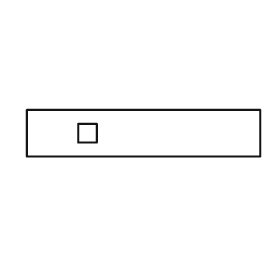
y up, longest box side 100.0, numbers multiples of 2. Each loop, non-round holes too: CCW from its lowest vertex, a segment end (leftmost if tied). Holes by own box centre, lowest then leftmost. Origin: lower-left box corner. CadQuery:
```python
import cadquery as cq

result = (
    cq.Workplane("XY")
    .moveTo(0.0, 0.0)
    .lineTo(100.0, 0.0)
    .lineTo(100.0, 20.0)
    .lineTo(0.0, 20.0)
    .close()
    .moveTo(22.0, 6.0)
    .lineTo(30.0, 6.0)
    .lineTo(30.0, 14.0)
    .lineTo(22.0, 14.0)
    .close()
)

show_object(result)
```